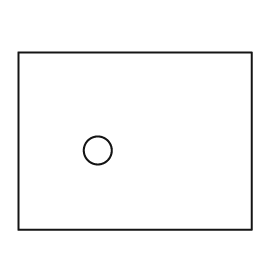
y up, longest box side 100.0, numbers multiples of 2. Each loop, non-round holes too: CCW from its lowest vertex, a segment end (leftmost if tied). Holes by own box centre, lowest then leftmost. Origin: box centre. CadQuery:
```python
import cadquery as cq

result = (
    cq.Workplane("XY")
    .moveTo(-50.0, -38.0)
    .lineTo(50.0, -38.0)
    .lineTo(50.0, 38.0)
    .lineTo(-50.0, 38.0)
    .close()
    .moveTo(-16.0, -4.0)
    .circle(6.0)
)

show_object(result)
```